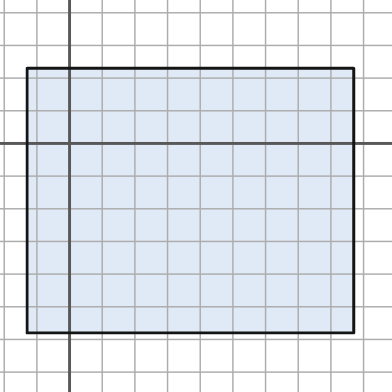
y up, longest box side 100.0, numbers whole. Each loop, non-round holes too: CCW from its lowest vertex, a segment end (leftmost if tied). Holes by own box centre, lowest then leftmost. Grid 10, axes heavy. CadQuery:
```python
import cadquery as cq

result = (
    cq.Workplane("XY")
    .moveTo(-13.0, -58.0)
    .lineTo(87.0, -58.0)
    .lineTo(87.0, 23.0)
    .lineTo(-13.0, 23.0)
    .close()
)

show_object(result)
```